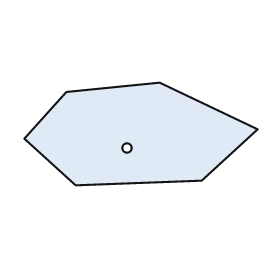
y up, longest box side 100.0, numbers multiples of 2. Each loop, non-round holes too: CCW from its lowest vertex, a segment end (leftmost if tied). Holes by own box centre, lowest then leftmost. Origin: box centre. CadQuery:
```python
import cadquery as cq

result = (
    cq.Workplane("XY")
    .moveTo(-28.0, -22.0)
    .lineTo(26.0, -20.0)
    .lineTo(50.0, 2.0)
    .lineTo(8.0, 22.0)
    .lineTo(-32.0, 18.0)
    .lineTo(-50.0, -2.0)
    .close()
    .moveTo(-6.0, -6.0)
    .circle(2.0)
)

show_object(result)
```